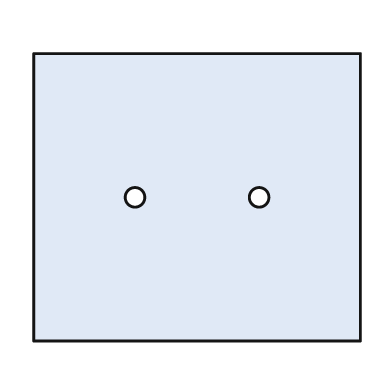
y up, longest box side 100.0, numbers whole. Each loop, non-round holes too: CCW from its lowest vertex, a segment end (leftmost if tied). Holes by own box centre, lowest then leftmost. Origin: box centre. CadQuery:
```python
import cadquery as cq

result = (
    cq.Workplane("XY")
    .moveTo(-50.0, -44.0)
    .lineTo(50.0, -44.0)
    .lineTo(50.0, 44.0)
    .lineTo(-50.0, 44.0)
    .close()
    .moveTo(-19.0, 0.0)
    .circle(3.0)
    .moveTo(19.0, 0.0)
    .circle(3.0)
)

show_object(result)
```